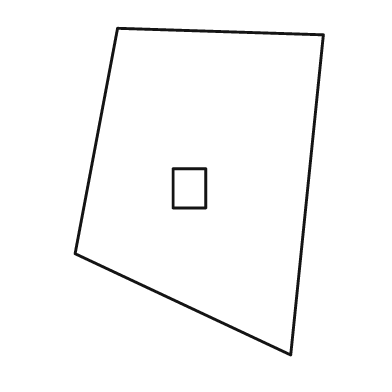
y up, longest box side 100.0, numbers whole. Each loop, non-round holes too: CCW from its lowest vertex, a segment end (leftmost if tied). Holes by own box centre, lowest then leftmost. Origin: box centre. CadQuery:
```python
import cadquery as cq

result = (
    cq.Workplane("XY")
    .moveTo(28.0, -50.0)
    .lineTo(38.0, 48.0)
    .lineTo(-25.0, 50.0)
    .lineTo(-38.0, -19.0)
    .close()
    .moveTo(-8.0, -5.0)
    .lineTo(2.0, -5.0)
    .lineTo(2.0, 7.0)
    .lineTo(-8.0, 7.0)
    .close()
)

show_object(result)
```